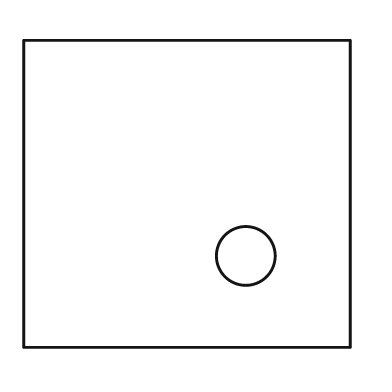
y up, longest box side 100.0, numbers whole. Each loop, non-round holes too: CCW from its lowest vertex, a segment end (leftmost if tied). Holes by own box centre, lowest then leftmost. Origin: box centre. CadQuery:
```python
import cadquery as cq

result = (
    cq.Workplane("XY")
    .moveTo(-50.0, -47.0)
    .lineTo(50.0, -47.0)
    .lineTo(50.0, 47.0)
    .lineTo(-50.0, 47.0)
    .close()
    .moveTo(18.0, -19.0)
    .circle(9.0)
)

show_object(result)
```